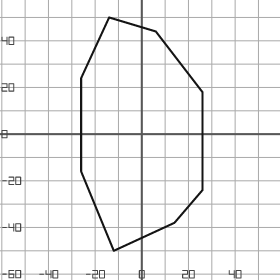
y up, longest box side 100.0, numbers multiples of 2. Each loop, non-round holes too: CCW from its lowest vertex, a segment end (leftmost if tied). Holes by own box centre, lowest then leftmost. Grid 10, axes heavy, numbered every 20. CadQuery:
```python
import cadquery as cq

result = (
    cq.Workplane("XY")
    .moveTo(-12.0, -50.0)
    .lineTo(14.0, -38.0)
    .lineTo(26.0, -24.0)
    .lineTo(26.0, 18.0)
    .lineTo(6.0, 44.0)
    .lineTo(-14.0, 50.0)
    .lineTo(-26.0, 24.0)
    .lineTo(-26.0, -16.0)
    .close()
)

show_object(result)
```